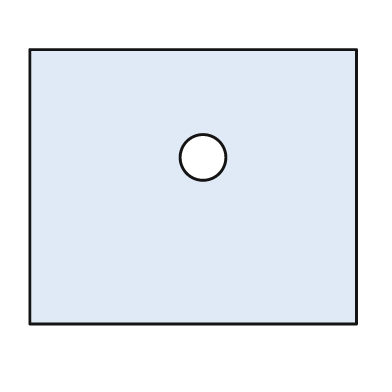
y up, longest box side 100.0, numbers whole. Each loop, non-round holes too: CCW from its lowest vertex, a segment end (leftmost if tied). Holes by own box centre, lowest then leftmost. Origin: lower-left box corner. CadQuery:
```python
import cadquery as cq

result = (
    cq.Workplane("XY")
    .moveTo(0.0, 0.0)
    .lineTo(100.0, 0.0)
    .lineTo(100.0, 84.0)
    .lineTo(0.0, 84.0)
    .close()
    .moveTo(53.0, 51.0)
    .circle(7.0)
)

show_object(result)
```